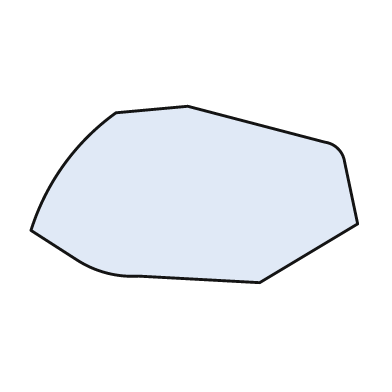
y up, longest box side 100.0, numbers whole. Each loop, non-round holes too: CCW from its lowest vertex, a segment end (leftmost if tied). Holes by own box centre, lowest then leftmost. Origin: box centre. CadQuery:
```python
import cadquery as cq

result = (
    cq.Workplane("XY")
    .moveTo(20.0, -27.0)
    .lineTo(50.0, -9.0)
    .lineTo(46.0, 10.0)
    .threePointArc((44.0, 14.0), (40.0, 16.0))
    .lineTo(-2.0, 27.0)
    .lineTo(-24.0, 25.0)
    .threePointArc((-40.0, 9.0), (-50.0, -11.0))
    .lineTo(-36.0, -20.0)
    .threePointArc((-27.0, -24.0), (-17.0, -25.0))
    .close()
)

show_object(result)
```